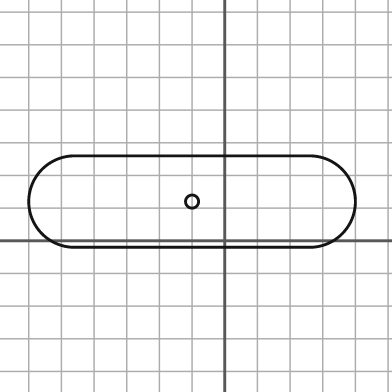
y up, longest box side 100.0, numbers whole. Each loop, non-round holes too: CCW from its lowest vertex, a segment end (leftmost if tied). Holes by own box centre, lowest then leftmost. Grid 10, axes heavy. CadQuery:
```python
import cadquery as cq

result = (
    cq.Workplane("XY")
    .moveTo(-46.0, -2.0)
    .lineTo(26.0, -2.0)
    .threePointArc((40.0, 12.0), (26.0, 26.0))
    .lineTo(-46.0, 26.0)
    .threePointArc((-60.0, 12.0), (-46.0, -2.0))
    .close()
    .moveTo(-10.0, 12.0)
    .circle(2.0)
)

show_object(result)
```